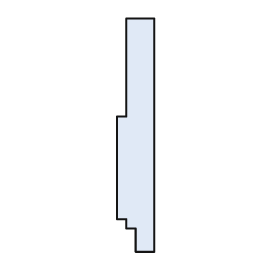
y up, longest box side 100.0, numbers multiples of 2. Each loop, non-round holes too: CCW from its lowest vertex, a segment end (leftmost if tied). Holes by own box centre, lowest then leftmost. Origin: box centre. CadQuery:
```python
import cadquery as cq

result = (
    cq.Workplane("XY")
    .moveTo(0.0, -50.0)
    .lineTo(8.0, -50.0)
    .lineTo(8.0, 50.0)
    .lineTo(-4.0, 50.0)
    .lineTo(-4.0, 8.0)
    .lineTo(-8.0, 8.0)
    .lineTo(-8.0, -36.0)
    .lineTo(-4.0, -36.0)
    .lineTo(-4.0, -40.0)
    .lineTo(0.0, -40.0)
    .close()
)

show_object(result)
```